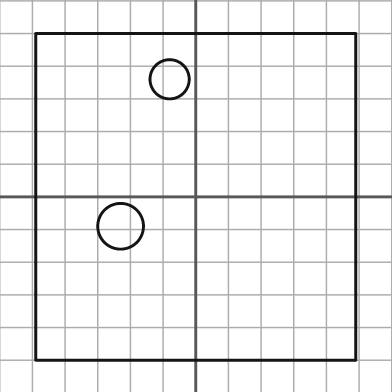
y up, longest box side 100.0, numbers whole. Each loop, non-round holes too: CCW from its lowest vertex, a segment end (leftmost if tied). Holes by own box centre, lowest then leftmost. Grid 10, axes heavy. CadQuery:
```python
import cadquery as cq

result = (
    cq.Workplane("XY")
    .moveTo(-49.0, -50.0)
    .lineTo(49.0, -50.0)
    .lineTo(49.0, 50.0)
    .lineTo(-49.0, 50.0)
    .close()
    .moveTo(-23.0, -9.0)
    .circle(7.0)
    .moveTo(-8.0, 36.0)
    .circle(6.0)
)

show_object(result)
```